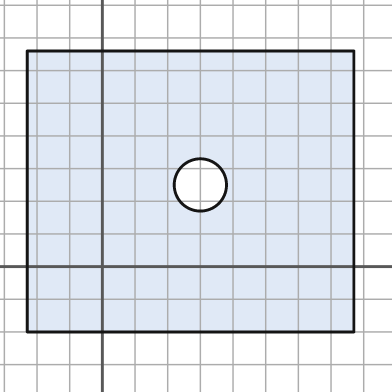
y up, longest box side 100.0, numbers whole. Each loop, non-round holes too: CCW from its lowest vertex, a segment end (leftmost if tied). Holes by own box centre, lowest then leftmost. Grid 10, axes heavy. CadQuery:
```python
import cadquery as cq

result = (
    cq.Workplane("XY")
    .moveTo(-23.0, -20.0)
    .lineTo(77.0, -20.0)
    .lineTo(77.0, 66.0)
    .lineTo(-23.0, 66.0)
    .close()
    .moveTo(30.0, 25.0)
    .circle(8.0)
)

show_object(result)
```